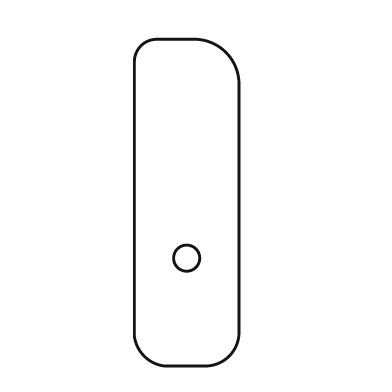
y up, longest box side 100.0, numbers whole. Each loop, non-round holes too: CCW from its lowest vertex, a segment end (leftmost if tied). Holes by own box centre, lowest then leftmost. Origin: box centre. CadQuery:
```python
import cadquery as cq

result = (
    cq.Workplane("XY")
    .moveTo(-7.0, -50.0)
    .lineTo(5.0, -50.0)
    .threePointArc((13.0, -47.0), (16.0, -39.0))
    .lineTo(16.0, 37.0)
    .threePointArc((12.0, 46.0), (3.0, 50.0))
    .lineTo(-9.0, 50.0)
    .threePointArc((-14.0, 48.0), (-16.0, 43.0))
    .lineTo(-16.0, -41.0)
    .threePointArc((-13.0, -47.0), (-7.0, -50.0))
    .close()
    .moveTo(0.0, -17.0)
    .circle(4.0)
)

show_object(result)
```